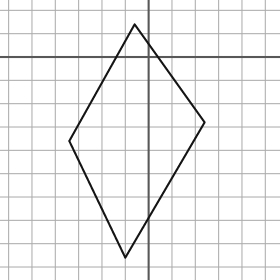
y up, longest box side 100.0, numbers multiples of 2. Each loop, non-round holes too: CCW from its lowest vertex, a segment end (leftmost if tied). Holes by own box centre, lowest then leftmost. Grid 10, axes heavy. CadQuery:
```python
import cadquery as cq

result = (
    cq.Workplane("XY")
    .moveTo(-10.0, -86.0)
    .lineTo(24.0, -28.0)
    .lineTo(-6.0, 14.0)
    .lineTo(-34.0, -36.0)
    .close()
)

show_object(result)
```